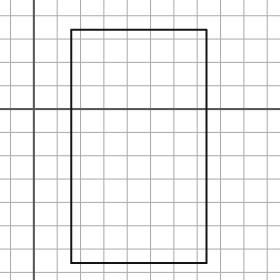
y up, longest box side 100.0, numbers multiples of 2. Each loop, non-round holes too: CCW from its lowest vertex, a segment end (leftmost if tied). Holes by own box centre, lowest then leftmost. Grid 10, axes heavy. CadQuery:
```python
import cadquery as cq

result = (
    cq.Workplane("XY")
    .moveTo(16.0, -66.0)
    .lineTo(74.0, -66.0)
    .lineTo(74.0, 34.0)
    .lineTo(16.0, 34.0)
    .close()
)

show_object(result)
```